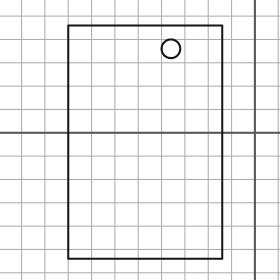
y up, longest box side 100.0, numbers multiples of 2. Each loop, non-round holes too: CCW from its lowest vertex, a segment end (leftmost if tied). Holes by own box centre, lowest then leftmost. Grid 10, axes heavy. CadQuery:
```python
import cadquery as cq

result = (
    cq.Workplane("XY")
    .moveTo(-80.0, -54.0)
    .lineTo(-14.0, -54.0)
    .lineTo(-14.0, 46.0)
    .lineTo(-80.0, 46.0)
    .close()
    .moveTo(-36.0, 36.0)
    .circle(4.0)
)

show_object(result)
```